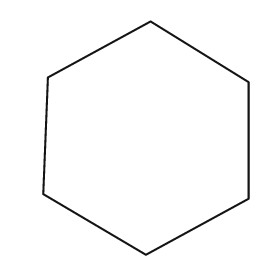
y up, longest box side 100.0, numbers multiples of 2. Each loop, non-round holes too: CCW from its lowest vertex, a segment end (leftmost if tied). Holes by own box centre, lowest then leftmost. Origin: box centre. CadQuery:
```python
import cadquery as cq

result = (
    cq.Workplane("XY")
    .moveTo(0.0, -50.0)
    .lineTo(44.0, -26.0)
    .lineTo(44.0, 24.0)
    .lineTo(2.0, 50.0)
    .lineTo(-42.0, 26.0)
    .lineTo(-44.0, -24.0)
    .close()
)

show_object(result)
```